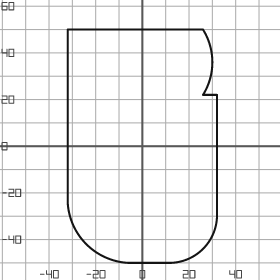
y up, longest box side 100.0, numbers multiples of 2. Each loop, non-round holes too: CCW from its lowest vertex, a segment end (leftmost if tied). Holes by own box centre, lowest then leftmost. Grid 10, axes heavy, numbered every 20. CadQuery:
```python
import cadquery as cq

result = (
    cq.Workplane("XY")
    .moveTo(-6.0, -50.0)
    .lineTo(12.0, -50.0)
    .threePointArc((26.0, -44.0), (32.0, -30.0))
    .lineTo(32.0, 22.0)
    .lineTo(26.0, 22.0)
    .threePointArc((30.0, 36.0), (26.0, 50.0))
    .lineTo(-32.0, 50.0)
    .lineTo(-32.0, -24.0)
    .threePointArc((-24.0, -42.0), (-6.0, -50.0))
    .close()
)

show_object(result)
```